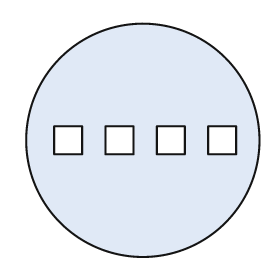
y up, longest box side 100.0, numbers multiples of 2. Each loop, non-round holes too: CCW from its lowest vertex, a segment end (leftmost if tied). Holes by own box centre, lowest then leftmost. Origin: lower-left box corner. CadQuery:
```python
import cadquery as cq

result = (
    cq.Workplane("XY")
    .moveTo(50.0, 50.0)
    .circle(50.0)
    .moveTo(12.0, 44.0)
    .lineTo(24.0, 44.0)
    .lineTo(24.0, 56.0)
    .lineTo(12.0, 56.0)
    .close()
    .moveTo(34.0, 44.0)
    .lineTo(46.0, 44.0)
    .lineTo(46.0, 56.0)
    .lineTo(34.0, 56.0)
    .close()
    .moveTo(56.0, 44.0)
    .lineTo(68.0, 44.0)
    .lineTo(68.0, 56.0)
    .lineTo(56.0, 56.0)
    .close()
    .moveTo(78.0, 44.0)
    .lineTo(90.0, 44.0)
    .lineTo(90.0, 56.0)
    .lineTo(78.0, 56.0)
    .close()
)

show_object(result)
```